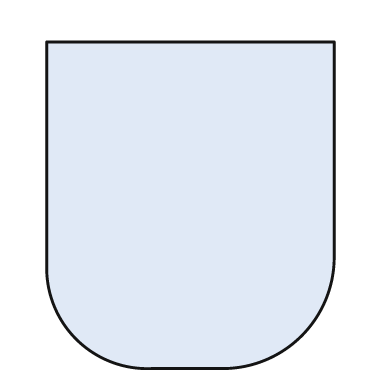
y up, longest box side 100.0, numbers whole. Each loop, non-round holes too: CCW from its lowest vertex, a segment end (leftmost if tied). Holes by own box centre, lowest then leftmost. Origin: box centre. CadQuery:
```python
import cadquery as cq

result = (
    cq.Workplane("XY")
    .moveTo(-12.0, -50.0)
    .lineTo(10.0, -50.0)
    .threePointArc((34.0, -40.0), (44.0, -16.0))
    .lineTo(44.0, 50.0)
    .lineTo(-44.0, 50.0)
    .lineTo(-44.0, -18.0)
    .threePointArc((-35.0, -41.0), (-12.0, -50.0))
    .close()
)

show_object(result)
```